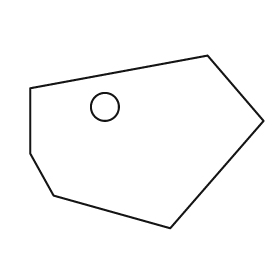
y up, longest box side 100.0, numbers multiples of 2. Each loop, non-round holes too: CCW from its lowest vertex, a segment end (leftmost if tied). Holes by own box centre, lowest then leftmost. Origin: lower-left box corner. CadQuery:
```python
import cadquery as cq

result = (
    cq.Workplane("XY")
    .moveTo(60.0, 0.0)
    .lineTo(100.0, 46.0)
    .lineTo(76.0, 74.0)
    .lineTo(0.0, 60.0)
    .lineTo(0.0, 32.0)
    .lineTo(10.0, 14.0)
    .close()
    .moveTo(32.0, 52.0)
    .circle(6.0)
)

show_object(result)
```